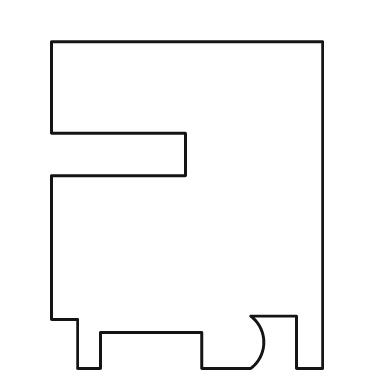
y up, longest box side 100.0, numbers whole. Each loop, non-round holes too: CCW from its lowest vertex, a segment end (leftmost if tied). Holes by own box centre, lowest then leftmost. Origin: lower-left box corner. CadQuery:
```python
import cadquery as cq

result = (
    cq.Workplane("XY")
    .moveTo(8.0, 0.0)
    .lineTo(15.0, 0.0)
    .lineTo(15.0, 11.0)
    .lineTo(46.0, 11.0)
    .lineTo(46.0, 0.0)
    .lineTo(61.0, 0.0)
    .threePointArc((65.0, 8.0), (61.0, 16.0))
    .lineTo(75.0, 16.0)
    .lineTo(75.0, 0.0)
    .lineTo(83.0, 0.0)
    .lineTo(83.0, 100.0)
    .lineTo(0.0, 100.0)
    .lineTo(0.0, 72.0)
    .lineTo(41.0, 72.0)
    .lineTo(41.0, 59.0)
    .lineTo(0.0, 59.0)
    .lineTo(0.0, 15.0)
    .lineTo(8.0, 15.0)
    .close()
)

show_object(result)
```